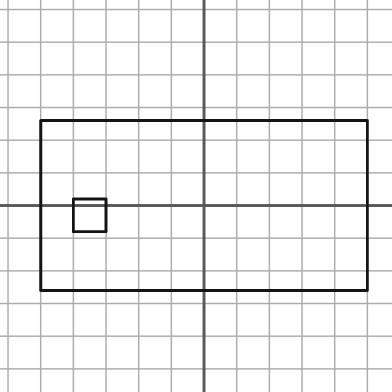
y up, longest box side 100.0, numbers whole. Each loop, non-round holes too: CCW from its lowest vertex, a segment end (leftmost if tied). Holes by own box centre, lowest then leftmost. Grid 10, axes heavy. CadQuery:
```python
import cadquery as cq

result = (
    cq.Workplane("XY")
    .moveTo(-50.0, -26.0)
    .lineTo(50.0, -26.0)
    .lineTo(50.0, 26.0)
    .lineTo(-50.0, 26.0)
    .close()
    .moveTo(-40.0, -8.0)
    .lineTo(-30.0, -8.0)
    .lineTo(-30.0, 2.0)
    .lineTo(-40.0, 2.0)
    .close()
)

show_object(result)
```